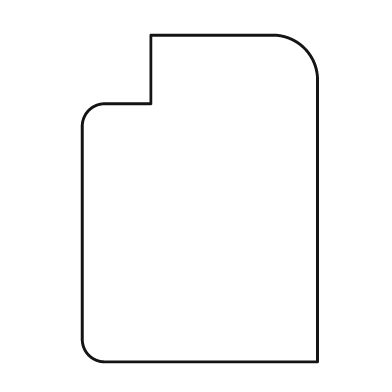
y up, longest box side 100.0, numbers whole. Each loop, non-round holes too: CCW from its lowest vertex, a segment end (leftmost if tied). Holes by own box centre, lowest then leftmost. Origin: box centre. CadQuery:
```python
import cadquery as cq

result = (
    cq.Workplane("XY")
    .moveTo(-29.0, -50.0)
    .lineTo(36.0, -50.0)
    .lineTo(36.0, 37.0)
    .threePointArc((32.0, 46.0), (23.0, 50.0))
    .lineTo(-15.0, 50.0)
    .lineTo(-15.0, 29.0)
    .lineTo(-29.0, 29.0)
    .threePointArc((-34.0, 27.0), (-36.0, 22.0))
    .lineTo(-36.0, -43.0)
    .threePointArc((-34.0, -48.0), (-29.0, -50.0))
    .close()
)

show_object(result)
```